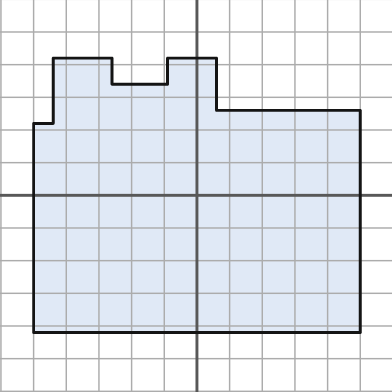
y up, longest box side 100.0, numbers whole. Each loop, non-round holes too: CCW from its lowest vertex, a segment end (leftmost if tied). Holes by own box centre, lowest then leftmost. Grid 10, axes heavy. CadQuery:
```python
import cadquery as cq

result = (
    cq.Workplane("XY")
    .moveTo(-50.0, -42.0)
    .lineTo(50.0, -42.0)
    .lineTo(50.0, 26.0)
    .lineTo(6.0, 26.0)
    .lineTo(6.0, 42.0)
    .lineTo(-9.0, 42.0)
    .lineTo(-9.0, 34.0)
    .lineTo(-26.0, 34.0)
    .lineTo(-26.0, 42.0)
    .lineTo(-44.0, 42.0)
    .lineTo(-44.0, 22.0)
    .lineTo(-50.0, 22.0)
    .close()
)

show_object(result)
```